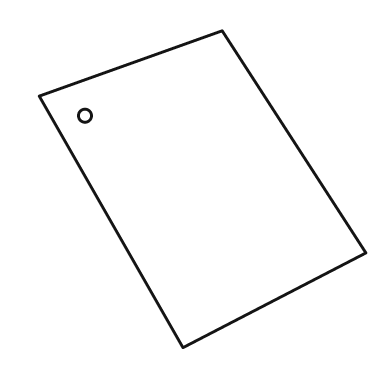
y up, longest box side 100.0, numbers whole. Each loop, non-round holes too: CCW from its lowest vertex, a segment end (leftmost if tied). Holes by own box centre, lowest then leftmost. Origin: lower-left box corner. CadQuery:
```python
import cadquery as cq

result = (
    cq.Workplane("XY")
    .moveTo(44.0, 0.0)
    .lineTo(100.0, 29.0)
    .lineTo(56.0, 97.0)
    .lineTo(0.0, 77.0)
    .close()
    .moveTo(14.0, 71.0)
    .circle(2.0)
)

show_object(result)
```